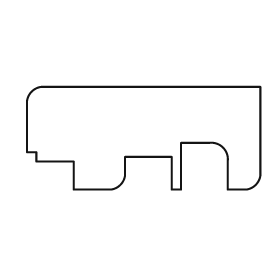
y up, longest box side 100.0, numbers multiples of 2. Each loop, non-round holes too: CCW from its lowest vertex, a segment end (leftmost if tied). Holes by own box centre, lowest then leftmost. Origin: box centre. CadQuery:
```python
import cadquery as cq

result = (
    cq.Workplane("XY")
    .moveTo(-30.0, -22.0)
    .lineTo(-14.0, -22.0)
    .threePointArc((-10.0, -20.0), (-8.0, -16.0))
    .lineTo(-8.0, -8.0)
    .lineTo(12.0, -8.0)
    .lineTo(12.0, -22.0)
    .lineTo(16.0, -22.0)
    .lineTo(16.0, -2.0)
    .lineTo(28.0, -2.0)
    .threePointArc((34.0, -4.0), (36.0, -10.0))
    .lineTo(36.0, -22.0)
    .lineTo(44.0, -22.0)
    .threePointArc((48.0, -20.0), (50.0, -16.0))
    .lineTo(50.0, 22.0)
    .lineTo(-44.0, 22.0)
    .threePointArc((-48.0, 20.0), (-50.0, 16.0))
    .lineTo(-50.0, -6.0)
    .lineTo(-46.0, -6.0)
    .lineTo(-46.0, -10.0)
    .lineTo(-30.0, -10.0)
    .close()
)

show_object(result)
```